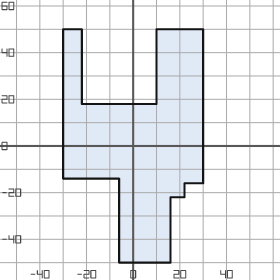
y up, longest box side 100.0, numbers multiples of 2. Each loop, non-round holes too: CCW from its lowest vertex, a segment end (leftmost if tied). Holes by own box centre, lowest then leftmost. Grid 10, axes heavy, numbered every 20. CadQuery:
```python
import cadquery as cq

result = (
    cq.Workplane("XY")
    .moveTo(-6.0, -50.0)
    .lineTo(16.0, -50.0)
    .lineTo(16.0, -22.0)
    .lineTo(22.0, -22.0)
    .lineTo(22.0, -16.0)
    .lineTo(30.0, -16.0)
    .lineTo(30.0, 50.0)
    .lineTo(10.0, 50.0)
    .lineTo(10.0, 18.0)
    .lineTo(-22.0, 18.0)
    .lineTo(-22.0, 50.0)
    .lineTo(-30.0, 50.0)
    .lineTo(-30.0, -14.0)
    .lineTo(-6.0, -14.0)
    .close()
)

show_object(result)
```